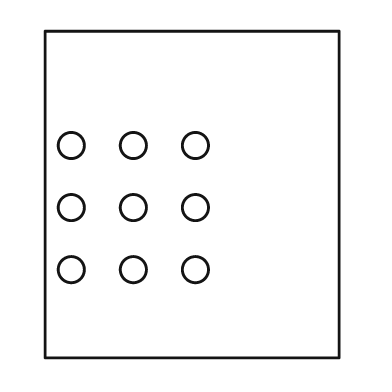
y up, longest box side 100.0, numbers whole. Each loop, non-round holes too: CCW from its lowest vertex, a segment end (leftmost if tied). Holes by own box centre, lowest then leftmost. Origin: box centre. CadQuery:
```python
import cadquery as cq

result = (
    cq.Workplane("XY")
    .moveTo(-45.0, -50.0)
    .lineTo(45.0, -50.0)
    .lineTo(45.0, 50.0)
    .lineTo(-45.0, 50.0)
    .close()
    .moveTo(-37.0, -23.0)
    .circle(4.0)
    .moveTo(-18.0, -23.0)
    .circle(4.0)
    .moveTo(1.0, -23.0)
    .circle(4.0)
    .moveTo(-37.0, -4.0)
    .circle(4.0)
    .moveTo(-18.0, -4.0)
    .circle(4.0)
    .moveTo(1.0, -4.0)
    .circle(4.0)
    .moveTo(-37.0, 15.0)
    .circle(4.0)
    .moveTo(-18.0, 15.0)
    .circle(4.0)
    .moveTo(1.0, 15.0)
    .circle(4.0)
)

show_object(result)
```